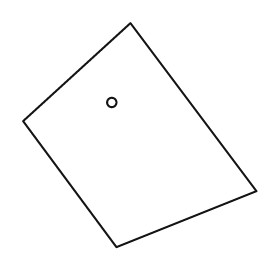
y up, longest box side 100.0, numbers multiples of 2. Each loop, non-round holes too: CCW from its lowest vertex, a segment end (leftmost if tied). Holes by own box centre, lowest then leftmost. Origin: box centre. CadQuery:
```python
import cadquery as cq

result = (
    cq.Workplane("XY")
    .moveTo(-10.0, -48.0)
    .lineTo(50.0, -24.0)
    .lineTo(-4.0, 48.0)
    .lineTo(-50.0, 6.0)
    .close()
    .moveTo(-12.0, 14.0)
    .circle(2.0)
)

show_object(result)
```